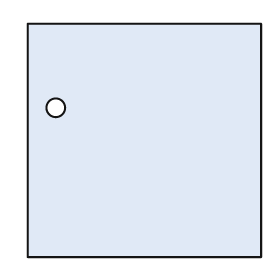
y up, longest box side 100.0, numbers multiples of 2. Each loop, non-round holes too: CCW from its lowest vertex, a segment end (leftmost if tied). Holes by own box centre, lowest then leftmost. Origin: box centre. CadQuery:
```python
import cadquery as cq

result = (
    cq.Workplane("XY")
    .moveTo(-50.0, -50.0)
    .lineTo(50.0, -50.0)
    .lineTo(50.0, 50.0)
    .lineTo(-50.0, 50.0)
    .close()
    .moveTo(-38.0, 14.0)
    .circle(4.0)
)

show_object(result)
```